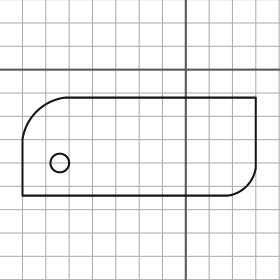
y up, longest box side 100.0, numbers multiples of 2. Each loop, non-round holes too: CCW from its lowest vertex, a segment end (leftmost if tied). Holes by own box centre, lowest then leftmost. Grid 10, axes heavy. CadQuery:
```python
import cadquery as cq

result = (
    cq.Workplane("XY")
    .moveTo(-70.0, -54.0)
    .lineTo(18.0, -54.0)
    .threePointArc((26.0, -50.0), (30.0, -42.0))
    .lineTo(30.0, -12.0)
    .lineTo(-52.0, -12.0)
    .threePointArc((-64.0, -18.0), (-70.0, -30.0))
    .close()
    .moveTo(-54.0, -40.0)
    .circle(4.0)
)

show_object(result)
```